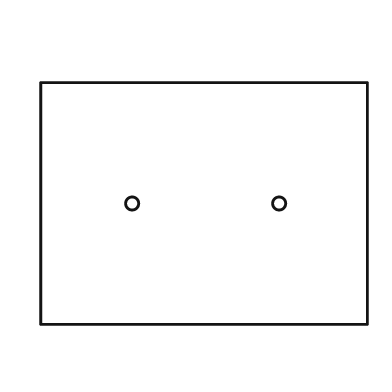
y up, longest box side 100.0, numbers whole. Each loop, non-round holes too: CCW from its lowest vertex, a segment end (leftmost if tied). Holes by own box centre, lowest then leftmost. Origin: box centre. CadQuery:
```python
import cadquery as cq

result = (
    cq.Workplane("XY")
    .moveTo(-50.0, -37.0)
    .lineTo(50.0, -37.0)
    .lineTo(50.0, 37.0)
    .lineTo(-50.0, 37.0)
    .close()
    .moveTo(-22.0, 0.0)
    .circle(2.0)
    .moveTo(23.0, 0.0)
    .circle(2.0)
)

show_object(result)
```